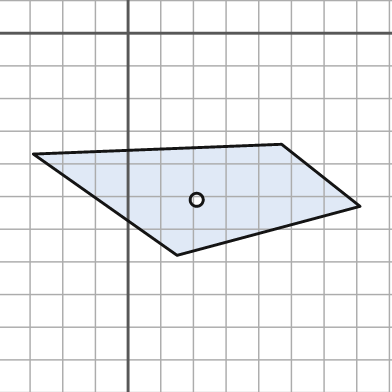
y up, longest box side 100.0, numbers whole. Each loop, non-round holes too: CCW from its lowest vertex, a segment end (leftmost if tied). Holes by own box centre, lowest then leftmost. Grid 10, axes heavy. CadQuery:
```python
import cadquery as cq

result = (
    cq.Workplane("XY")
    .moveTo(15.0, -68.0)
    .lineTo(71.0, -53.0)
    .lineTo(47.0, -34.0)
    .lineTo(-29.0, -37.0)
    .close()
    .moveTo(21.0, -51.0)
    .circle(2.0)
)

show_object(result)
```